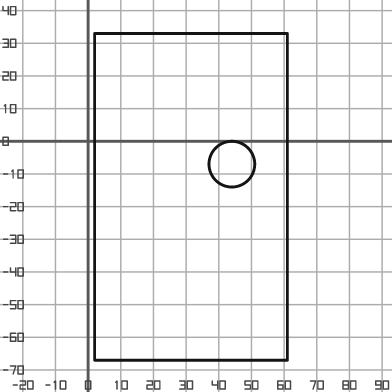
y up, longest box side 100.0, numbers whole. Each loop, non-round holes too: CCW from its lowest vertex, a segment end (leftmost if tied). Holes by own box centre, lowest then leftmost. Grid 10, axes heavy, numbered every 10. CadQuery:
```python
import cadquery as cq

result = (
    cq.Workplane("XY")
    .moveTo(2.0, -67.0)
    .lineTo(61.0, -67.0)
    .lineTo(61.0, 33.0)
    .lineTo(2.0, 33.0)
    .close()
    .moveTo(44.0, -7.0)
    .circle(7.0)
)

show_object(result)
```